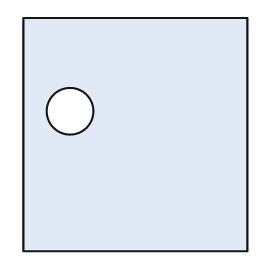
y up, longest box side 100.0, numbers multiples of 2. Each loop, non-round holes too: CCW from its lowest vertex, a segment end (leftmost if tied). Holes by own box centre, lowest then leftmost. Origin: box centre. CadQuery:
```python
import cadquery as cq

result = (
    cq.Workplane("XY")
    .moveTo(-48.0, -50.0)
    .lineTo(48.0, -50.0)
    .lineTo(48.0, 50.0)
    .lineTo(-48.0, 50.0)
    .close()
    .moveTo(-28.0, 10.0)
    .circle(10.0)
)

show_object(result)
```